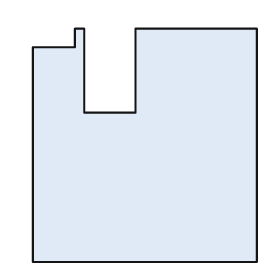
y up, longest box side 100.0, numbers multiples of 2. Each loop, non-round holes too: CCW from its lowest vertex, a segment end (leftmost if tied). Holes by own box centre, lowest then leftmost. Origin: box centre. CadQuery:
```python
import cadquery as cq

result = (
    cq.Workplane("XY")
    .moveTo(-48.0, -50.0)
    .lineTo(48.0, -50.0)
    .lineTo(48.0, 50.0)
    .lineTo(-4.0, 50.0)
    .lineTo(-4.0, 14.0)
    .lineTo(-26.0, 14.0)
    .lineTo(-26.0, 50.0)
    .lineTo(-30.0, 50.0)
    .lineTo(-30.0, 42.0)
    .lineTo(-48.0, 42.0)
    .close()
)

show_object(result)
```